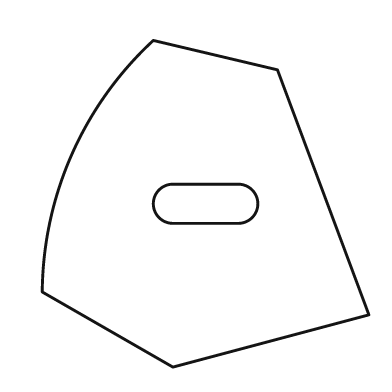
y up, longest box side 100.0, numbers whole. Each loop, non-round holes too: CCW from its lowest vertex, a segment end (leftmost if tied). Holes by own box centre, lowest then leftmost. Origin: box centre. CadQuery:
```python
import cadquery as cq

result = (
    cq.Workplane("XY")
    .moveTo(-10.0, -50.0)
    .lineTo(50.0, -34.0)
    .lineTo(22.0, 41.0)
    .lineTo(-16.0, 50.0)
    .threePointArc((-41.0, 15.0), (-50.0, -27.0))
    .close()
    .moveTo(-10.0, -6.0)
    .lineTo(10.0, -6.0)
    .threePointArc((16.0, 0.0), (10.0, 6.0))
    .lineTo(-10.0, 6.0)
    .threePointArc((-16.0, 0.0), (-10.0, -6.0))
    .close()
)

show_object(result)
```